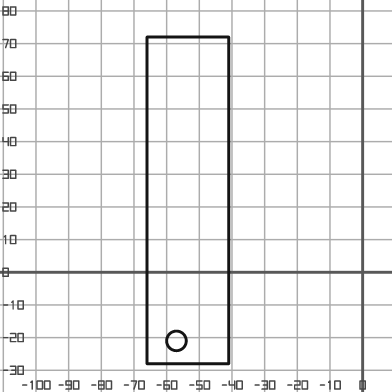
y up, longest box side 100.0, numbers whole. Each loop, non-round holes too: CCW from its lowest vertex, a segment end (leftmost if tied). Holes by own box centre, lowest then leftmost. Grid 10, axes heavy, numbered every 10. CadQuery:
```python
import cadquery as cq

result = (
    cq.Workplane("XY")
    .moveTo(-66.0, -28.0)
    .lineTo(-41.0, -28.0)
    .lineTo(-41.0, 72.0)
    .lineTo(-66.0, 72.0)
    .close()
    .moveTo(-57.0, -21.0)
    .circle(3.0)
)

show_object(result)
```